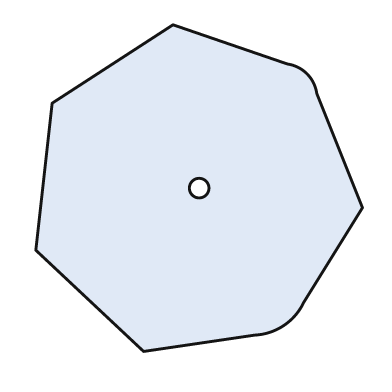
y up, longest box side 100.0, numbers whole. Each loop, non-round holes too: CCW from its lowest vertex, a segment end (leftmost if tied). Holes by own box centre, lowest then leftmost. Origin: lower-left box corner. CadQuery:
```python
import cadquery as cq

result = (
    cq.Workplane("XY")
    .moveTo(33.0, 0.0)
    .lineTo(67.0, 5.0)
    .threePointArc((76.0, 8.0), (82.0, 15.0))
    .lineTo(100.0, 44.0)
    .lineTo(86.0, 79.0)
    .threePointArc((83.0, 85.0), (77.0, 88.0))
    .lineTo(42.0, 100.0)
    .lineTo(5.0, 76.0)
    .lineTo(0.0, 31.0)
    .close()
    .moveTo(50.0, 50.0)
    .circle(3.0)
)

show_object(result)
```